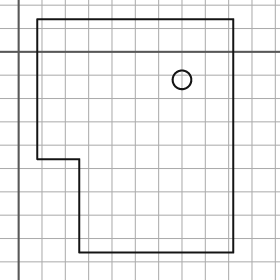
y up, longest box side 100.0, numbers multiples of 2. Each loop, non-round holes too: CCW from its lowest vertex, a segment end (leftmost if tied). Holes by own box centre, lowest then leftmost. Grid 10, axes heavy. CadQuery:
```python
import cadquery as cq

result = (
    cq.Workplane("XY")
    .moveTo(26.0, -86.0)
    .lineTo(92.0, -86.0)
    .lineTo(92.0, 14.0)
    .lineTo(8.0, 14.0)
    .lineTo(8.0, -46.0)
    .lineTo(26.0, -46.0)
    .close()
    .moveTo(70.0, -12.0)
    .circle(4.0)
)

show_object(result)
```